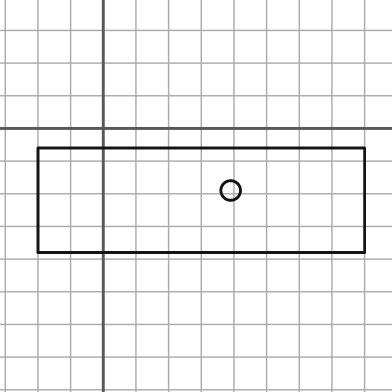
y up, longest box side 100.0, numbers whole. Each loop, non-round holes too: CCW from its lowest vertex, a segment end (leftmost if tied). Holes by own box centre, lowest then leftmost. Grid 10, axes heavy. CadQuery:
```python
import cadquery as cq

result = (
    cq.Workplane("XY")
    .moveTo(-20.0, -38.0)
    .lineTo(80.0, -38.0)
    .lineTo(80.0, -6.0)
    .lineTo(-20.0, -6.0)
    .close()
    .moveTo(39.0, -19.0)
    .circle(3.0)
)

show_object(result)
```